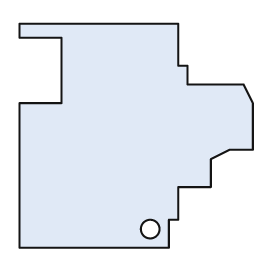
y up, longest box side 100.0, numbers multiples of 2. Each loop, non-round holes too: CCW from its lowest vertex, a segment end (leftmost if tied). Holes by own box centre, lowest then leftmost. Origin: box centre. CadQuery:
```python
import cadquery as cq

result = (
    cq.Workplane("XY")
    .moveTo(-50.0, -48.0)
    .lineTo(14.0, -48.0)
    .lineTo(14.0, -36.0)
    .lineTo(18.0, -36.0)
    .lineTo(18.0, -22.0)
    .lineTo(32.0, -22.0)
    .lineTo(32.0, -10.0)
    .lineTo(40.0, -6.0)
    .lineTo(50.0, -6.0)
    .lineTo(50.0, 14.0)
    .lineTo(46.0, 22.0)
    .lineTo(22.0, 22.0)
    .lineTo(22.0, 30.0)
    .lineTo(18.0, 30.0)
    .lineTo(18.0, 48.0)
    .lineTo(-50.0, 48.0)
    .lineTo(-50.0, 42.0)
    .lineTo(-32.0, 42.0)
    .lineTo(-32.0, 14.0)
    .lineTo(-50.0, 14.0)
    .close()
    .moveTo(6.0, -40.0)
    .circle(4.0)
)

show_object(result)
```